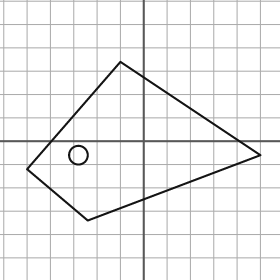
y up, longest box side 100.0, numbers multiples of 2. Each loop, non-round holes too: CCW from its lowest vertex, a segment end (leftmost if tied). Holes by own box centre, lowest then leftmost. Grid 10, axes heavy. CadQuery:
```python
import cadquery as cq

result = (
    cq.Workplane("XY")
    .moveTo(-24.0, -34.0)
    .lineTo(50.0, -6.0)
    .lineTo(-10.0, 34.0)
    .lineTo(-50.0, -12.0)
    .close()
    .moveTo(-28.0, -6.0)
    .circle(4.0)
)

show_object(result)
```